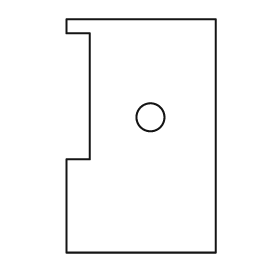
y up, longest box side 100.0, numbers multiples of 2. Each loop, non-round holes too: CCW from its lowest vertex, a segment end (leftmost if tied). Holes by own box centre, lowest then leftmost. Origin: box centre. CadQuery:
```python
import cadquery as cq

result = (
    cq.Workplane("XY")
    .moveTo(-32.0, -50.0)
    .lineTo(32.0, -50.0)
    .lineTo(32.0, 50.0)
    .lineTo(-32.0, 50.0)
    .lineTo(-32.0, 44.0)
    .lineTo(-22.0, 44.0)
    .lineTo(-22.0, -10.0)
    .lineTo(-32.0, -10.0)
    .close()
    .moveTo(4.0, 8.0)
    .circle(6.0)
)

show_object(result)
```